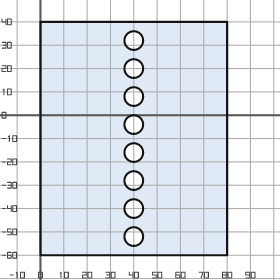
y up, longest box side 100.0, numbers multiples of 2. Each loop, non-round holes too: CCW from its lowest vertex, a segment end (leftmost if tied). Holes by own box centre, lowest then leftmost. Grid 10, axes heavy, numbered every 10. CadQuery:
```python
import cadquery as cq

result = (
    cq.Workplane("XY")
    .moveTo(0.0, -60.0)
    .lineTo(80.0, -60.0)
    .lineTo(80.0, 40.0)
    .lineTo(0.0, 40.0)
    .close()
    .moveTo(40.0, -52.0)
    .circle(4.0)
    .moveTo(40.0, -40.0)
    .circle(4.0)
    .moveTo(40.0, -28.0)
    .circle(4.0)
    .moveTo(40.0, -16.0)
    .circle(4.0)
    .moveTo(40.0, -4.0)
    .circle(4.0)
    .moveTo(40.0, 8.0)
    .circle(4.0)
    .moveTo(40.0, 20.0)
    .circle(4.0)
    .moveTo(40.0, 32.0)
    .circle(4.0)
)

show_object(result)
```